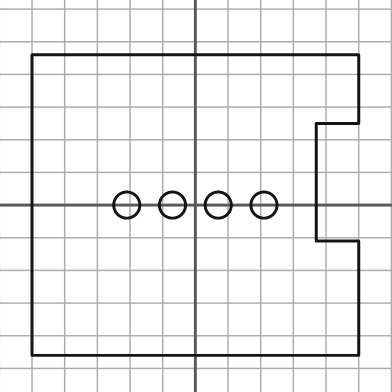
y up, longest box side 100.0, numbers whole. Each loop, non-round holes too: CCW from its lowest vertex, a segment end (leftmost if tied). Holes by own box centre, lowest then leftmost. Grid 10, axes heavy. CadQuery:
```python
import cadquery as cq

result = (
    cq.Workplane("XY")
    .moveTo(-50.0, -46.0)
    .lineTo(50.0, -46.0)
    .lineTo(50.0, -11.0)
    .lineTo(37.0, -11.0)
    .lineTo(37.0, 25.0)
    .lineTo(50.0, 25.0)
    .lineTo(50.0, 46.0)
    .lineTo(-50.0, 46.0)
    .close()
    .moveTo(-21.0, 0.0)
    .circle(4.0)
    .moveTo(-7.0, 0.0)
    .circle(4.0)
    .moveTo(7.0, 0.0)
    .circle(4.0)
    .moveTo(21.0, 0.0)
    .circle(4.0)
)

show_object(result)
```